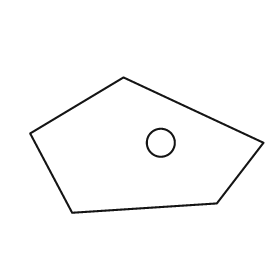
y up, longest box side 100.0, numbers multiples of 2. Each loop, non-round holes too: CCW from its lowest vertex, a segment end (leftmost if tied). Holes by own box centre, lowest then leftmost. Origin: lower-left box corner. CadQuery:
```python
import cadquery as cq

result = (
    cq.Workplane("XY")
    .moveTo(18.0, 0.0)
    .lineTo(80.0, 4.0)
    .lineTo(100.0, 30.0)
    .lineTo(40.0, 58.0)
    .lineTo(0.0, 34.0)
    .close()
    .moveTo(56.0, 30.0)
    .circle(6.0)
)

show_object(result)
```